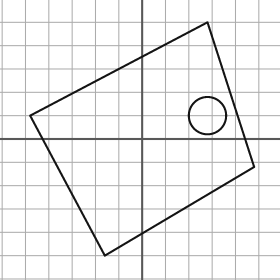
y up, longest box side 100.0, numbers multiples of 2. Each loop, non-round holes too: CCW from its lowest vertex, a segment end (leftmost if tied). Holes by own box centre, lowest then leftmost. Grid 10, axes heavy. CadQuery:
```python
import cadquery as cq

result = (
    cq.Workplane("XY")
    .moveTo(-16.0, -50.0)
    .lineTo(48.0, -12.0)
    .lineTo(28.0, 50.0)
    .lineTo(-48.0, 10.0)
    .close()
    .moveTo(28.0, 10.0)
    .circle(8.0)
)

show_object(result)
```